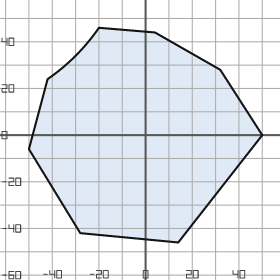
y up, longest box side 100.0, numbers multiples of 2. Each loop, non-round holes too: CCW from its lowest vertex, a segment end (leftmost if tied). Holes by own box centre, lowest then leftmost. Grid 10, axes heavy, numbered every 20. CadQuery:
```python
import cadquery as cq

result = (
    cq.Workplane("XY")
    .moveTo(14.0, -46.0)
    .lineTo(50.0, 0.0)
    .lineTo(32.0, 28.0)
    .lineTo(4.0, 44.0)
    .lineTo(-20.0, 46.0)
    .threePointArc((-30.0, 34.0), (-42.0, 24.0))
    .lineTo(-50.0, -6.0)
    .lineTo(-28.0, -42.0)
    .close()
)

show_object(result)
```